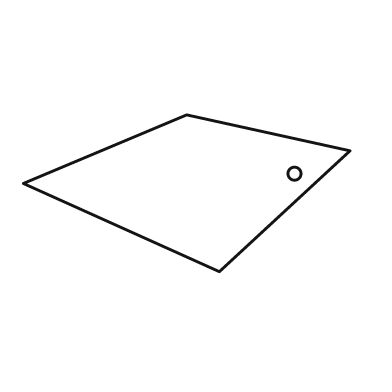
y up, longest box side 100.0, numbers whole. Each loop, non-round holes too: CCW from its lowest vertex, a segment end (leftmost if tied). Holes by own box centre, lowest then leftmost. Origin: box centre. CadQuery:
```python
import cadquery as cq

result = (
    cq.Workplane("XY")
    .moveTo(10.0, -24.0)
    .lineTo(50.0, 13.0)
    .lineTo(0.0, 24.0)
    .lineTo(-50.0, 3.0)
    .close()
    .moveTo(33.0, 6.0)
    .circle(2.0)
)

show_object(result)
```